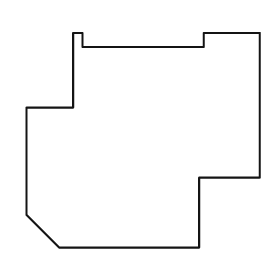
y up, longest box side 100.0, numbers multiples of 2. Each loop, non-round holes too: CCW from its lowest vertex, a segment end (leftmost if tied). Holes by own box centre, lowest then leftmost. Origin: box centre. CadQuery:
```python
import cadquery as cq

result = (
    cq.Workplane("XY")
    .moveTo(-36.0, -46.0)
    .lineTo(24.0, -46.0)
    .lineTo(24.0, -16.0)
    .lineTo(50.0, -16.0)
    .lineTo(50.0, 46.0)
    .lineTo(26.0, 46.0)
    .lineTo(26.0, 40.0)
    .lineTo(-26.0, 40.0)
    .lineTo(-26.0, 46.0)
    .lineTo(-30.0, 46.0)
    .lineTo(-30.0, 14.0)
    .lineTo(-50.0, 14.0)
    .lineTo(-50.0, -32.0)
    .close()
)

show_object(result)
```